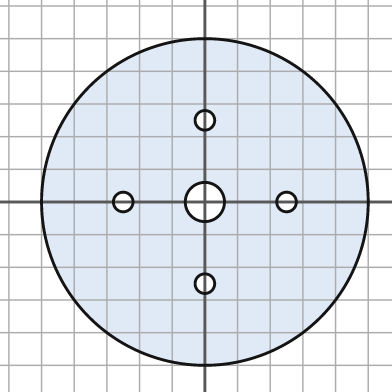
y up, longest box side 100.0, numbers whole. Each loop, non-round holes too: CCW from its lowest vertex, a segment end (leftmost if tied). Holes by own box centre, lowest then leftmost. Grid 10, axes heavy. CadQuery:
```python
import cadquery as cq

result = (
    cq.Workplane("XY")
    .moveTo(0.0, 0.0)
    .circle(50.0)
    .moveTo(0.0, -25.0)
    .circle(3.0)
    .moveTo(-25.0, 0.0)
    .circle(3.0)
    .moveTo(0.0, 0.0)
    .circle(6.0)
    .moveTo(25.0, 0.0)
    .circle(3.0)
    .moveTo(0.0, 25.0)
    .circle(3.0)
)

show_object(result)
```